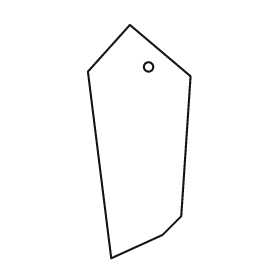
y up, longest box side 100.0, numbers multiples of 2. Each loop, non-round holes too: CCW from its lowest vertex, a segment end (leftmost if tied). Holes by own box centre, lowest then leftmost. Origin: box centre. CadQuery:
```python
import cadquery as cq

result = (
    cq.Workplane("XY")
    .moveTo(-12.0, -50.0)
    .lineTo(10.0, -40.0)
    .lineTo(18.0, -32.0)
    .lineTo(22.0, 28.0)
    .lineTo(-4.0, 50.0)
    .lineTo(-22.0, 30.0)
    .close()
    .moveTo(4.0, 32.0)
    .circle(2.0)
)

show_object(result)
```